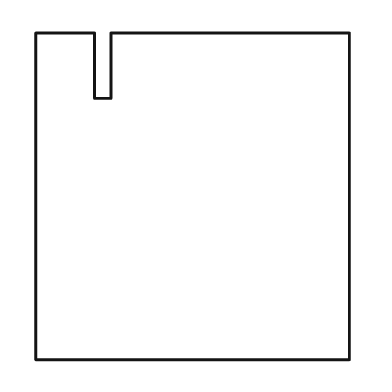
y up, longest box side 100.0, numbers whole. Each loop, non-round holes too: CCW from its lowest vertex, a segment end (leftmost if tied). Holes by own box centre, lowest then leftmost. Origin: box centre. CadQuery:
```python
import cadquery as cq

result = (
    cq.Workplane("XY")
    .moveTo(-48.0, -50.0)
    .lineTo(48.0, -50.0)
    .lineTo(48.0, 50.0)
    .lineTo(-25.0, 50.0)
    .lineTo(-25.0, 30.0)
    .lineTo(-30.0, 30.0)
    .lineTo(-30.0, 50.0)
    .lineTo(-48.0, 50.0)
    .close()
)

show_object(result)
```